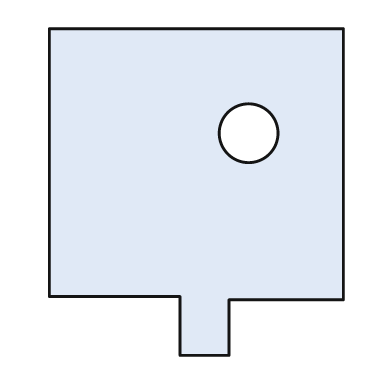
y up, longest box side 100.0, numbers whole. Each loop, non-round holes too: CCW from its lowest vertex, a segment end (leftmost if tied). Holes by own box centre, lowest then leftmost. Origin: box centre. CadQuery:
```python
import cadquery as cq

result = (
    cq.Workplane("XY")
    .moveTo(-5.0, -50.0)
    .lineTo(10.0, -50.0)
    .lineTo(10.0, -33.0)
    .lineTo(45.0, -33.0)
    .lineTo(45.0, 50.0)
    .lineTo(-45.0, 50.0)
    .lineTo(-45.0, -32.0)
    .lineTo(-5.0, -32.0)
    .close()
    .moveTo(16.0, 18.0)
    .circle(9.0)
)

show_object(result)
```